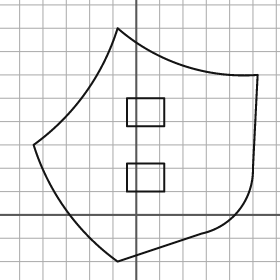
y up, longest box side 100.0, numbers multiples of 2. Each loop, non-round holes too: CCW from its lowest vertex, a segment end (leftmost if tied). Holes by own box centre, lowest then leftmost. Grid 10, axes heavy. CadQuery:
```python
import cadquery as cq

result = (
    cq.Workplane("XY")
    .moveTo(-8.0, -20.0)
    .lineTo(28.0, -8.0)
    .threePointArc((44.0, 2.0), (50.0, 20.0))
    .lineTo(52.0, 60.0)
    .threePointArc((20.0, 64.0), (-8.0, 80.0))
    .threePointArc((-22.0, 52.0), (-44.0, 30.0))
    .threePointArc((-30.0, 2.0), (-8.0, -20.0))
    .close()
    .moveTo(-4.0, 10.0)
    .lineTo(12.0, 10.0)
    .lineTo(12.0, 22.0)
    .lineTo(-4.0, 22.0)
    .close()
    .moveTo(-4.0, 38.0)
    .lineTo(12.0, 38.0)
    .lineTo(12.0, 50.0)
    .lineTo(-4.0, 50.0)
    .close()
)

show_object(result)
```